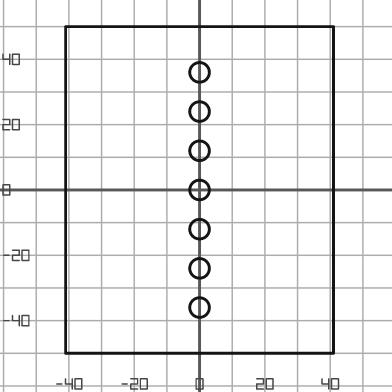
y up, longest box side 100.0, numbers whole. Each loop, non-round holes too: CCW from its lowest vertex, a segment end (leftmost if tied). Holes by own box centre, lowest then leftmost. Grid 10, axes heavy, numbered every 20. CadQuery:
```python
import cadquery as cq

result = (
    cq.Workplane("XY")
    .moveTo(-41.0, -50.0)
    .lineTo(41.0, -50.0)
    .lineTo(41.0, 50.0)
    .lineTo(-41.0, 50.0)
    .close()
    .moveTo(0.0, -36.0)
    .circle(3.0)
    .moveTo(0.0, -24.0)
    .circle(3.0)
    .moveTo(0.0, -12.0)
    .circle(3.0)
    .moveTo(0.0, 0.0)
    .circle(3.0)
    .moveTo(0.0, 12.0)
    .circle(3.0)
    .moveTo(0.0, 24.0)
    .circle(3.0)
    .moveTo(0.0, 36.0)
    .circle(3.0)
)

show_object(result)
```